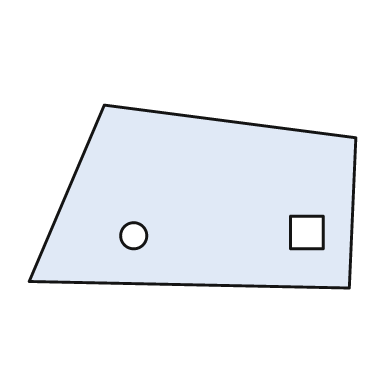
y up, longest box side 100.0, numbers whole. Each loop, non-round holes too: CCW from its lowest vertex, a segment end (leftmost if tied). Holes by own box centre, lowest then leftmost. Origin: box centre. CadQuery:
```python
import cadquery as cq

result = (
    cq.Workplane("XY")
    .moveTo(48.0, -28.0)
    .lineTo(50.0, 18.0)
    .lineTo(-27.0, 28.0)
    .lineTo(-50.0, -26.0)
    .close()
    .moveTo(-18.0, -12.0)
    .circle(4.0)
    .moveTo(30.0, -16.0)
    .lineTo(40.0, -16.0)
    .lineTo(40.0, -6.0)
    .lineTo(30.0, -6.0)
    .close()
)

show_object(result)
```